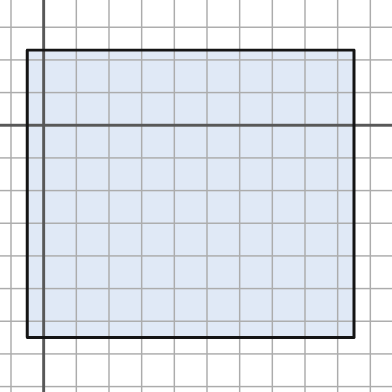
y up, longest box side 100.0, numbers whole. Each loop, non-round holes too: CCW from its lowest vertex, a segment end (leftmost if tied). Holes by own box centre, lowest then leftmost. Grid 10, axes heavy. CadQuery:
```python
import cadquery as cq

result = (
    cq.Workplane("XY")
    .moveTo(-5.0, -65.0)
    .lineTo(95.0, -65.0)
    .lineTo(95.0, 23.0)
    .lineTo(-5.0, 23.0)
    .close()
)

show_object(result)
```